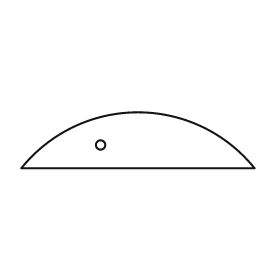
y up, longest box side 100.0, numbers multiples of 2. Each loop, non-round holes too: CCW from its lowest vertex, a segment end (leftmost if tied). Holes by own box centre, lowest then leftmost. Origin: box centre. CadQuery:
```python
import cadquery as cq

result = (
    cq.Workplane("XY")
    .moveTo(-50.0, -12.0)
    .lineTo(50.0, -12.0)
    .threePointArc((0.0, 12.0), (-50.0, -12.0))
    .close()
    .moveTo(-16.0, -2.0)
    .circle(2.0)
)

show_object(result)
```